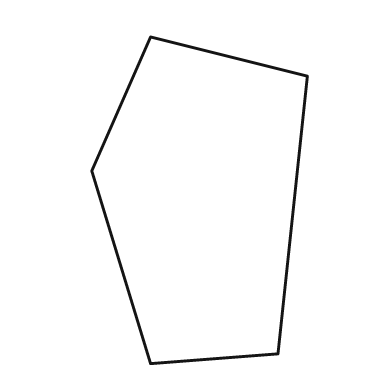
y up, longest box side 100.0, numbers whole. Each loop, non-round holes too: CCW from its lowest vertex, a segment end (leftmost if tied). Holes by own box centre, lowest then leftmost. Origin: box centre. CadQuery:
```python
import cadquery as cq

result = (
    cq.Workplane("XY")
    .moveTo(-15.0, -50.0)
    .lineTo(24.0, -47.0)
    .lineTo(33.0, 38.0)
    .lineTo(-15.0, 50.0)
    .lineTo(-33.0, 9.0)
    .close()
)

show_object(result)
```